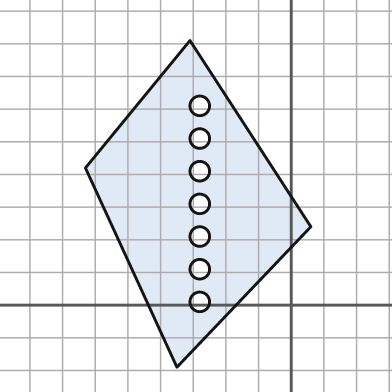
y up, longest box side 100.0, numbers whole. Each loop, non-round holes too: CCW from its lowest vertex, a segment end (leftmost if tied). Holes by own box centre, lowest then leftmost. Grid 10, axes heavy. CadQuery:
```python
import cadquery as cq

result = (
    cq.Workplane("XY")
    .moveTo(-35.0, -19.0)
    .lineTo(6.0, 24.0)
    .lineTo(-31.0, 81.0)
    .lineTo(-63.0, 42.0)
    .close()
    .moveTo(-28.0, 1.0)
    .circle(3.0)
    .moveTo(-28.0, 11.0)
    .circle(3.0)
    .moveTo(-28.0, 21.0)
    .circle(3.0)
    .moveTo(-28.0, 31.0)
    .circle(3.0)
    .moveTo(-28.0, 41.0)
    .circle(3.0)
    .moveTo(-28.0, 51.0)
    .circle(3.0)
    .moveTo(-28.0, 61.0)
    .circle(3.0)
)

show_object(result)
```